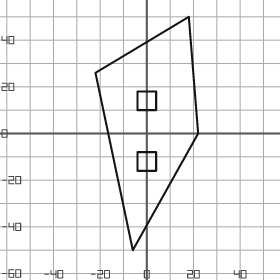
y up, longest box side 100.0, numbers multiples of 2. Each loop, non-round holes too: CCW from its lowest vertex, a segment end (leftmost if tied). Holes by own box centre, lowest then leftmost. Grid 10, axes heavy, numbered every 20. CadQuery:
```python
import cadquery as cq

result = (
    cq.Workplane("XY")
    .moveTo(-6.0, -50.0)
    .lineTo(22.0, 0.0)
    .lineTo(18.0, 50.0)
    .lineTo(-22.0, 26.0)
    .close()
    .moveTo(-4.0, -16.0)
    .lineTo(4.0, -16.0)
    .lineTo(4.0, -8.0)
    .lineTo(-4.0, -8.0)
    .close()
    .moveTo(-4.0, 10.0)
    .lineTo(4.0, 10.0)
    .lineTo(4.0, 18.0)
    .lineTo(-4.0, 18.0)
    .close()
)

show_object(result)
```